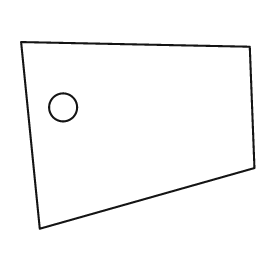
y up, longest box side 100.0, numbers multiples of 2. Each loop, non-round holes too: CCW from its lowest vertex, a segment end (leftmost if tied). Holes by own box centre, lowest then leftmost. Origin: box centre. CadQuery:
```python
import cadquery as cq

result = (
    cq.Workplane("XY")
    .moveTo(-42.0, -40.0)
    .lineTo(50.0, -14.0)
    .lineTo(48.0, 38.0)
    .lineTo(-50.0, 40.0)
    .close()
    .moveTo(-32.0, 12.0)
    .circle(6.0)
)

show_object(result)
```